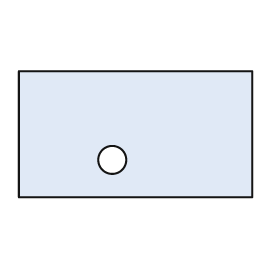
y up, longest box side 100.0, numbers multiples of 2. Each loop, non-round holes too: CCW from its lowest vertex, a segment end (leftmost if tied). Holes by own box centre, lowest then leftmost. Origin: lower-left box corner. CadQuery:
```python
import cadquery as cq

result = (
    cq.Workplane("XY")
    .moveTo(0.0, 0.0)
    .lineTo(100.0, 0.0)
    .lineTo(100.0, 54.0)
    .lineTo(0.0, 54.0)
    .close()
    .moveTo(40.0, 16.0)
    .circle(6.0)
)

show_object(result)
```